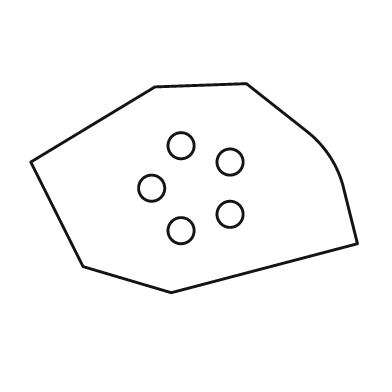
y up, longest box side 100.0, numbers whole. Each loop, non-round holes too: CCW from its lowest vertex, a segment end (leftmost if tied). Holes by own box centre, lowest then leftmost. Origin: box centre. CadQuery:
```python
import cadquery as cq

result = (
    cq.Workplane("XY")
    .moveTo(-7.0, -32.0)
    .lineTo(50.0, -17.0)
    .lineTo(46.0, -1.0)
    .threePointArc((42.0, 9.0), (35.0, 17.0))
    .lineTo(16.0, 32.0)
    .lineTo(-12.0, 31.0)
    .lineTo(-50.0, 8.0)
    .lineTo(-34.0, -24.0)
    .close()
    .moveTo(-4.0, -13.0)
    .circle(4.0)
    .moveTo(11.0, -8.0)
    .circle(4.0)
    .moveTo(-13.0, 0.0)
    .circle(4.0)
    .moveTo(11.0, 8.0)
    .circle(4.0)
    .moveTo(-4.0, 13.0)
    .circle(4.0)
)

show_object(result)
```